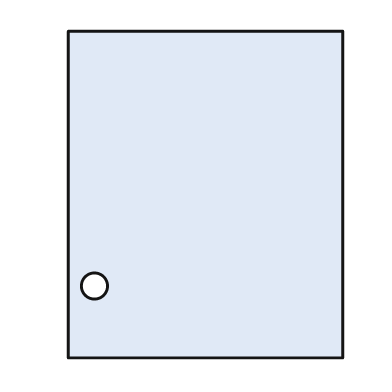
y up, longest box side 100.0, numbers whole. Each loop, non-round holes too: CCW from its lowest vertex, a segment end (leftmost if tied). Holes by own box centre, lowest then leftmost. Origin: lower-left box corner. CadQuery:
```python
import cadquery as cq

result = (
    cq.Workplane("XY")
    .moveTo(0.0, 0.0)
    .lineTo(84.0, 0.0)
    .lineTo(84.0, 100.0)
    .lineTo(0.0, 100.0)
    .close()
    .moveTo(8.0, 22.0)
    .circle(4.0)
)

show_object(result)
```